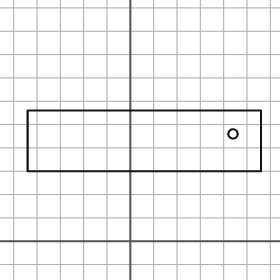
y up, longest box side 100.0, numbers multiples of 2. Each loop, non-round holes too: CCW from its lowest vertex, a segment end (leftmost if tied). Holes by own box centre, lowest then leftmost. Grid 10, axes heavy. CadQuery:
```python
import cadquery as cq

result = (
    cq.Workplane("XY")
    .moveTo(-44.0, 30.0)
    .lineTo(56.0, 30.0)
    .lineTo(56.0, 56.0)
    .lineTo(-44.0, 56.0)
    .close()
    .moveTo(44.0, 46.0)
    .circle(2.0)
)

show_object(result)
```